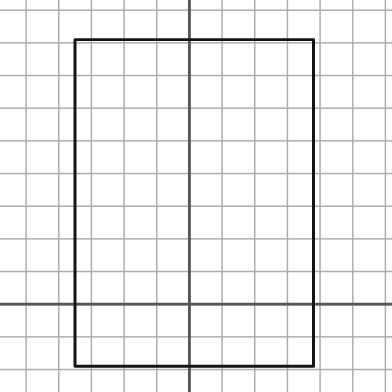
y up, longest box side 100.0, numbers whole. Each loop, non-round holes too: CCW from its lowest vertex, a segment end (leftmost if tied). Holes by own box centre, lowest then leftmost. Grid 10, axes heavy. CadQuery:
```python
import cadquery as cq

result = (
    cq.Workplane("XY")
    .moveTo(-35.0, -19.0)
    .lineTo(38.0, -19.0)
    .lineTo(38.0, 81.0)
    .lineTo(-35.0, 81.0)
    .close()
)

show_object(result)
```